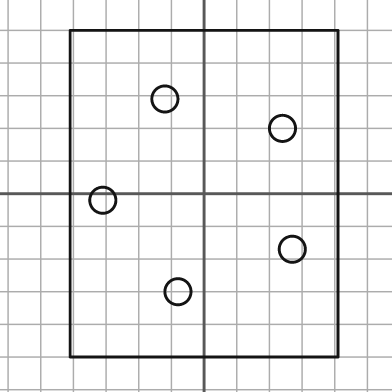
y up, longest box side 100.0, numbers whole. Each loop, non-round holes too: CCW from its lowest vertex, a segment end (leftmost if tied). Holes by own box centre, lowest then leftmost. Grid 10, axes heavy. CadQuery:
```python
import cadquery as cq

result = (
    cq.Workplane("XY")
    .moveTo(-41.0, -50.0)
    .lineTo(41.0, -50.0)
    .lineTo(41.0, 50.0)
    .lineTo(-41.0, 50.0)
    .close()
    .moveTo(-8.0, -30.0)
    .circle(4.0)
    .moveTo(27.0, -17.0)
    .circle(4.0)
    .moveTo(-31.0, -2.0)
    .circle(4.0)
    .moveTo(24.0, 20.0)
    .circle(4.0)
    .moveTo(-12.0, 29.0)
    .circle(4.0)
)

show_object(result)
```